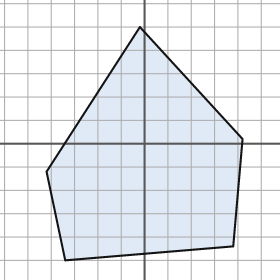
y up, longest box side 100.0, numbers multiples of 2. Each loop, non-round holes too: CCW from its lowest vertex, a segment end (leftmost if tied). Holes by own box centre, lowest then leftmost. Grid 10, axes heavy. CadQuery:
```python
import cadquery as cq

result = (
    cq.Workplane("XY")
    .moveTo(-34.0, -50.0)
    .lineTo(38.0, -44.0)
    .lineTo(42.0, 2.0)
    .lineTo(-2.0, 50.0)
    .lineTo(-42.0, -12.0)
    .close()
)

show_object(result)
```